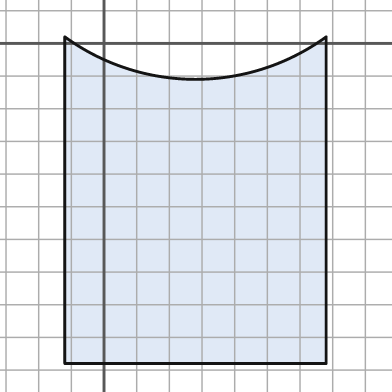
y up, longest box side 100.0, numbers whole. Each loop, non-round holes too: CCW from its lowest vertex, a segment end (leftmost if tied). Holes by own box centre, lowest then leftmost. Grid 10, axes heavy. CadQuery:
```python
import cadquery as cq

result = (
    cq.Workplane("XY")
    .moveTo(-12.0, -98.0)
    .lineTo(68.0, -98.0)
    .lineTo(68.0, 2.0)
    .threePointArc((28.0, -11.0), (-12.0, 2.0))
    .close()
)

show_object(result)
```